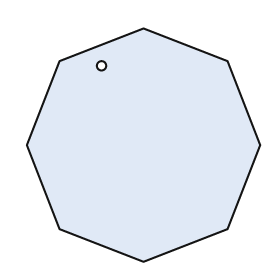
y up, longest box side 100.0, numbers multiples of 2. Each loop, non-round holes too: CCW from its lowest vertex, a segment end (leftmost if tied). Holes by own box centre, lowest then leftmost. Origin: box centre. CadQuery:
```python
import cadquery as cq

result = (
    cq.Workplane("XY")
    .moveTo(0.0, -50.0)
    .lineTo(36.0, -36.0)
    .lineTo(50.0, 0.0)
    .lineTo(36.0, 36.0)
    .lineTo(0.0, 50.0)
    .lineTo(-36.0, 36.0)
    .lineTo(-50.0, 0.0)
    .lineTo(-36.0, -36.0)
    .close()
    .moveTo(-18.0, 34.0)
    .circle(2.0)
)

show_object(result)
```